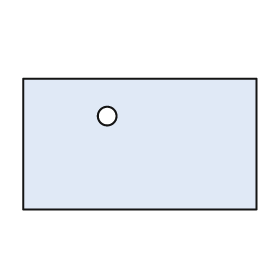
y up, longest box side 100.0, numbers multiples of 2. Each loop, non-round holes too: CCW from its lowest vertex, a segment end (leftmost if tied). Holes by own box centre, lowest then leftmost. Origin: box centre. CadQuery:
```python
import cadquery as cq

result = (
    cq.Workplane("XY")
    .moveTo(-50.0, -28.0)
    .lineTo(50.0, -28.0)
    .lineTo(50.0, 28.0)
    .lineTo(-50.0, 28.0)
    .close()
    .moveTo(-14.0, 12.0)
    .circle(4.0)
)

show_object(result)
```